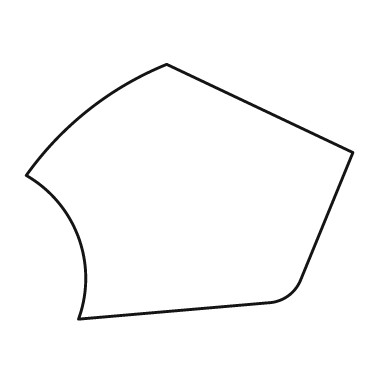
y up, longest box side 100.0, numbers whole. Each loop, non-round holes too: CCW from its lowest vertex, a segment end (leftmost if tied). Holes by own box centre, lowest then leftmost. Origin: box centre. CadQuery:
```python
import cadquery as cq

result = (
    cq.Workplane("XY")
    .moveTo(-34.0, -39.0)
    .lineTo(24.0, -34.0)
    .threePointArc((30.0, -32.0), (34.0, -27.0))
    .lineTo(50.0, 12.0)
    .lineTo(-7.0, 39.0)
    .threePointArc((-31.0, 25.0), (-50.0, 5.0))
    .threePointArc((-34.0, -14.0), (-34.0, -39.0))
    .close()
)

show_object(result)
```